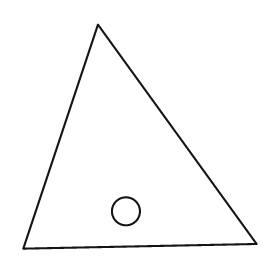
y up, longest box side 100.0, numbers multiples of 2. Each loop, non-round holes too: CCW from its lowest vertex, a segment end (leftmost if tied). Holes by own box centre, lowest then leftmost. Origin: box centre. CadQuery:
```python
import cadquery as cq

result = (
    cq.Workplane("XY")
    .moveTo(-50.0, -48.0)
    .lineTo(50.0, -46.0)
    .lineTo(-18.0, 48.0)
    .close()
    .moveTo(-6.0, -32.0)
    .circle(6.0)
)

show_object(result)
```